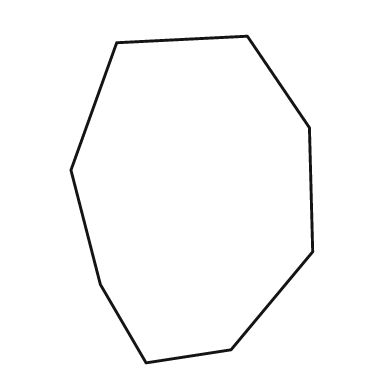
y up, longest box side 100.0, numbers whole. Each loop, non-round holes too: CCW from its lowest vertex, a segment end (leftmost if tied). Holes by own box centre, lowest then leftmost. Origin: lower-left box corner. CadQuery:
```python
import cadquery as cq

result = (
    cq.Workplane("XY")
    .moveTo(23.0, 0.0)
    .lineTo(49.0, 4.0)
    .lineTo(74.0, 34.0)
    .lineTo(73.0, 72.0)
    .lineTo(54.0, 100.0)
    .lineTo(14.0, 98.0)
    .lineTo(0.0, 59.0)
    .lineTo(9.0, 24.0)
    .close()
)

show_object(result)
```